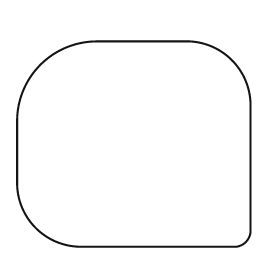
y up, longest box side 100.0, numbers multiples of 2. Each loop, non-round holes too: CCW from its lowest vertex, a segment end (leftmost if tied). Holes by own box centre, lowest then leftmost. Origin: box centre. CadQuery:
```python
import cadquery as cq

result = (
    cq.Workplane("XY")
    .moveTo(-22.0, -44.0)
    .lineTo(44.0, -44.0)
    .threePointArc((48.0, -42.0), (50.0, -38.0))
    .lineTo(50.0, 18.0)
    .threePointArc((42.0, 36.0), (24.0, 44.0))
    .lineTo(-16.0, 44.0)
    .threePointArc((-40.0, 34.0), (-50.0, 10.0))
    .lineTo(-50.0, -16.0)
    .threePointArc((-42.0, -36.0), (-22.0, -44.0))
    .close()
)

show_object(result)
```